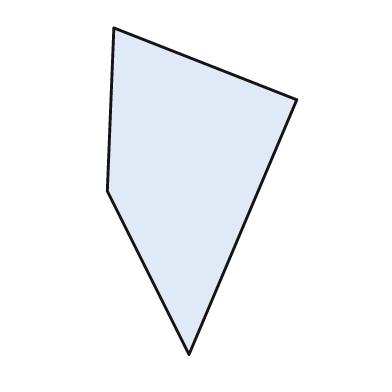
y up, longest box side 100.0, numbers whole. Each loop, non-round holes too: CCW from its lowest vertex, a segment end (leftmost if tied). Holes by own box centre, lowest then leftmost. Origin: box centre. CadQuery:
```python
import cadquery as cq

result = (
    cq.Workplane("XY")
    .moveTo(-4.0, -50.0)
    .lineTo(29.0, 28.0)
    .lineTo(-27.0, 50.0)
    .lineTo(-29.0, 0.0)
    .close()
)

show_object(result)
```